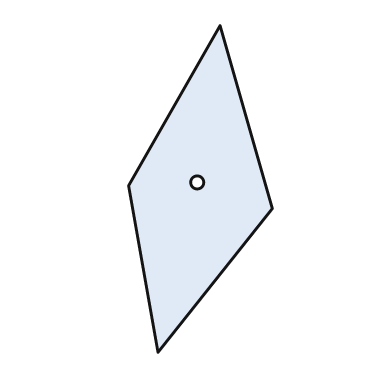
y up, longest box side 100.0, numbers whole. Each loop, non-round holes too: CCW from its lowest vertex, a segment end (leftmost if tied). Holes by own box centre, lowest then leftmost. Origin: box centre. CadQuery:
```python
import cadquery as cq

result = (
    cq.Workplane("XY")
    .moveTo(-13.0, -50.0)
    .lineTo(22.0, -6.0)
    .lineTo(6.0, 50.0)
    .lineTo(-22.0, 1.0)
    .close()
    .moveTo(-1.0, 2.0)
    .circle(2.0)
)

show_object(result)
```